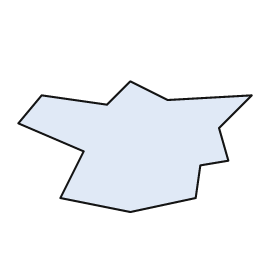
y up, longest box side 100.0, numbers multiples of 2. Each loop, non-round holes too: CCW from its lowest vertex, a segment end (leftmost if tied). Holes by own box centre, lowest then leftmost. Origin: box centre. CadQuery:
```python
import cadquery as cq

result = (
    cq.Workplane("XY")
    .moveTo(-2.0, -28.0)
    .lineTo(26.0, -22.0)
    .lineTo(28.0, -8.0)
    .lineTo(40.0, -6.0)
    .lineTo(36.0, 8.0)
    .lineTo(50.0, 22.0)
    .lineTo(14.0, 20.0)
    .lineTo(-2.0, 28.0)
    .lineTo(-12.0, 18.0)
    .lineTo(-40.0, 22.0)
    .lineTo(-50.0, 10.0)
    .lineTo(-22.0, -2.0)
    .lineTo(-32.0, -22.0)
    .close()
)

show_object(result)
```